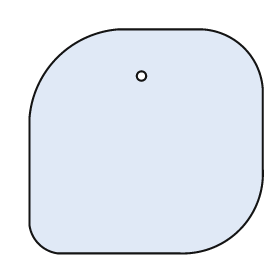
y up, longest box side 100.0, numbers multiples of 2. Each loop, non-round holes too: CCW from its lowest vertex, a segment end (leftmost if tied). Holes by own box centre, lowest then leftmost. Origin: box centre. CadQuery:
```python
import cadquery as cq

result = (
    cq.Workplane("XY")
    .moveTo(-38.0, -48.0)
    .lineTo(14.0, -48.0)
    .threePointArc((40.0, -38.0), (50.0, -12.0))
    .lineTo(50.0, 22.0)
    .threePointArc((42.0, 40.0), (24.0, 48.0))
    .lineTo(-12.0, 48.0)
    .threePointArc((-38.0, 36.0), (-50.0, 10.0))
    .lineTo(-50.0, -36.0)
    .threePointArc((-46.0, -44.0), (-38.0, -48.0))
    .close()
    .moveTo(-2.0, 28.0)
    .circle(2.0)
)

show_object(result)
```